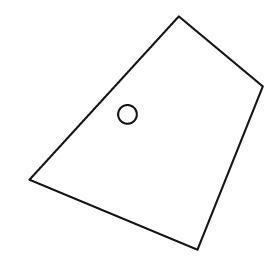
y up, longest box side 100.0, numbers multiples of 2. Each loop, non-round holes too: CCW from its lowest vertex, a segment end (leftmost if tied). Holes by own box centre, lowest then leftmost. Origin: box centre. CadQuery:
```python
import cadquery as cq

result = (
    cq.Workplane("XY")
    .moveTo(22.0, -50.0)
    .lineTo(50.0, 20.0)
    .lineTo(14.0, 50.0)
    .lineTo(-50.0, -20.0)
    .close()
    .moveTo(-8.0, 8.0)
    .circle(4.0)
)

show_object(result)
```